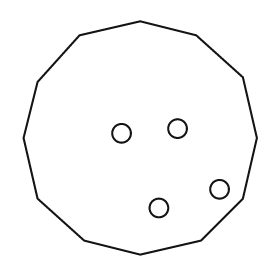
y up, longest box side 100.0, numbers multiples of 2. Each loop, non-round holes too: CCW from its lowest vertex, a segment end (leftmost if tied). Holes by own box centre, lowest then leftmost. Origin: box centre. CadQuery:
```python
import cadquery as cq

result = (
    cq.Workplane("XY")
    .moveTo(0.0, -50.0)
    .lineTo(26.0, -44.0)
    .lineTo(44.0, -26.0)
    .lineTo(50.0, 0.0)
    .lineTo(44.0, 26.0)
    .lineTo(24.0, 44.0)
    .lineTo(0.0, 50.0)
    .lineTo(-26.0, 44.0)
    .lineTo(-44.0, 24.0)
    .lineTo(-50.0, 0.0)
    .lineTo(-44.0, -26.0)
    .lineTo(-24.0, -44.0)
    .close()
    .moveTo(8.0, -30.0)
    .circle(4.0)
    .moveTo(34.0, -22.0)
    .circle(4.0)
    .moveTo(-8.0, 2.0)
    .circle(4.0)
    .moveTo(16.0, 4.0)
    .circle(4.0)
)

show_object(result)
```